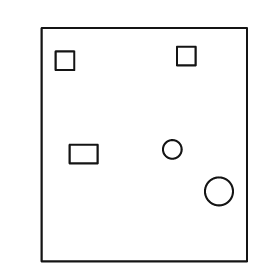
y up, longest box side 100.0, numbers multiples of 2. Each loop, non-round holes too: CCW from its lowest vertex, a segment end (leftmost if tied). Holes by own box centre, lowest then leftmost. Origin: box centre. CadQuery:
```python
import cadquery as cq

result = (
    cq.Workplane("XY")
    .moveTo(-44.0, -50.0)
    .lineTo(44.0, -50.0)
    .lineTo(44.0, 50.0)
    .lineTo(-44.0, 50.0)
    .close()
    .moveTo(32.0, -20.0)
    .circle(6.0)
    .moveTo(-32.0, -8.0)
    .lineTo(-20.0, -8.0)
    .lineTo(-20.0, 0.0)
    .lineTo(-32.0, 0.0)
    .close()
    .moveTo(12.0, -2.0)
    .circle(4.0)
    .moveTo(-38.0, 32.0)
    .lineTo(-30.0, 32.0)
    .lineTo(-30.0, 40.0)
    .lineTo(-38.0, 40.0)
    .close()
    .moveTo(14.0, 34.0)
    .lineTo(22.0, 34.0)
    .lineTo(22.0, 42.0)
    .lineTo(14.0, 42.0)
    .close()
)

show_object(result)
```